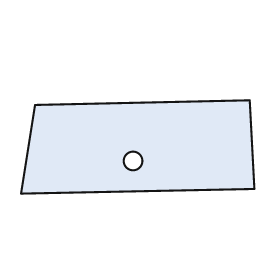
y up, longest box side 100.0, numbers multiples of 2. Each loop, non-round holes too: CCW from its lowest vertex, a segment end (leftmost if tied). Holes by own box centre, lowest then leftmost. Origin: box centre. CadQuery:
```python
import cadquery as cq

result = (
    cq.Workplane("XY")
    .moveTo(-50.0, -20.0)
    .lineTo(50.0, -18.0)
    .lineTo(48.0, 20.0)
    .lineTo(-44.0, 18.0)
    .close()
    .moveTo(-2.0, -6.0)
    .circle(4.0)
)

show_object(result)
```